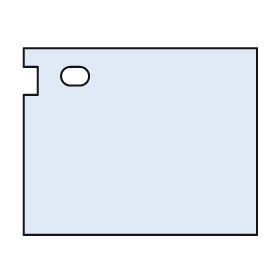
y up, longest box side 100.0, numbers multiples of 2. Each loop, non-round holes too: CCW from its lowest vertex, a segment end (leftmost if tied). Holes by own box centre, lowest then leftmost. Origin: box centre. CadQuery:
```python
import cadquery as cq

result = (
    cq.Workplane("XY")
    .moveTo(-50.0, -40.0)
    .lineTo(50.0, -40.0)
    .lineTo(50.0, 40.0)
    .lineTo(-50.0, 40.0)
    .lineTo(-50.0, 32.0)
    .lineTo(-44.0, 32.0)
    .lineTo(-44.0, 20.0)
    .lineTo(-50.0, 20.0)
    .close()
    .moveTo(-30.0, 24.0)
    .lineTo(-26.0, 24.0)
    .threePointArc((-22.0, 28.0), (-26.0, 32.0))
    .lineTo(-30.0, 32.0)
    .threePointArc((-34.0, 28.0), (-30.0, 24.0))
    .close()
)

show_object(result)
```